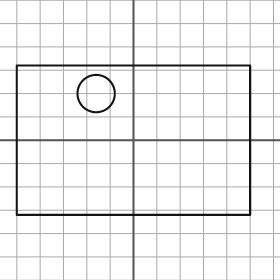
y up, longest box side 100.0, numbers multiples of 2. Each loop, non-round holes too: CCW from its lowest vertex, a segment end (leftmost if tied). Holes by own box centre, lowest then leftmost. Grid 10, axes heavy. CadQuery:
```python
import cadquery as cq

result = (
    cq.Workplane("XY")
    .moveTo(-50.0, -32.0)
    .lineTo(50.0, -32.0)
    .lineTo(50.0, 32.0)
    .lineTo(-50.0, 32.0)
    .close()
    .moveTo(-16.0, 20.0)
    .circle(8.0)
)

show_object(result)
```